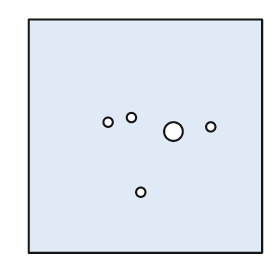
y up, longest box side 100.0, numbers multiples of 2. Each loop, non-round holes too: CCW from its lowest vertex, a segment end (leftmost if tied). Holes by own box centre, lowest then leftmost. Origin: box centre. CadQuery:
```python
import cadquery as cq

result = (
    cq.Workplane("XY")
    .moveTo(-50.0, -50.0)
    .lineTo(50.0, -50.0)
    .lineTo(50.0, 50.0)
    .lineTo(-50.0, 50.0)
    .close()
    .moveTo(-2.0, -24.0)
    .circle(2.0)
    .moveTo(12.0, 2.0)
    .circle(4.0)
    .moveTo(28.0, 4.0)
    .circle(2.0)
    .moveTo(-16.0, 6.0)
    .circle(2.0)
    .moveTo(-6.0, 8.0)
    .circle(2.0)
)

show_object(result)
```